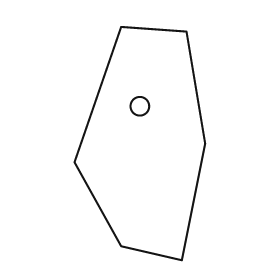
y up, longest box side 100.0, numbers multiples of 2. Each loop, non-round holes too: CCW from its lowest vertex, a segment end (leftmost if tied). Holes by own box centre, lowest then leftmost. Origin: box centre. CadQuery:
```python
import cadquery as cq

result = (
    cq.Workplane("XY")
    .moveTo(18.0, -50.0)
    .lineTo(28.0, 0.0)
    .lineTo(20.0, 48.0)
    .lineTo(-8.0, 50.0)
    .lineTo(-28.0, -8.0)
    .lineTo(-8.0, -44.0)
    .close()
    .moveTo(0.0, 16.0)
    .circle(4.0)
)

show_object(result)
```